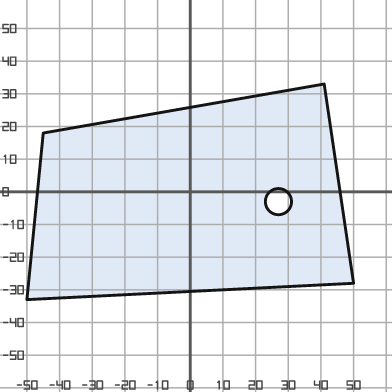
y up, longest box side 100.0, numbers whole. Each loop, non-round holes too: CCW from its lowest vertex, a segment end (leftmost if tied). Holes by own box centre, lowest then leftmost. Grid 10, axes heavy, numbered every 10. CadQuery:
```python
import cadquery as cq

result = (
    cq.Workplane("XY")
    .moveTo(-50.0, -33.0)
    .lineTo(50.0, -28.0)
    .lineTo(41.0, 33.0)
    .lineTo(-45.0, 18.0)
    .close()
    .moveTo(27.0, -3.0)
    .circle(4.0)
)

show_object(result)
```